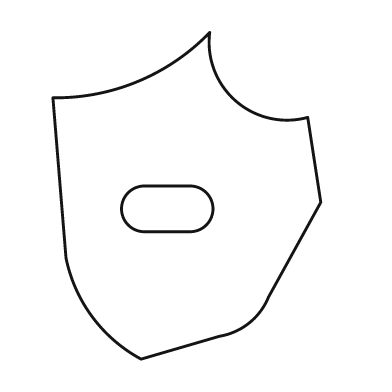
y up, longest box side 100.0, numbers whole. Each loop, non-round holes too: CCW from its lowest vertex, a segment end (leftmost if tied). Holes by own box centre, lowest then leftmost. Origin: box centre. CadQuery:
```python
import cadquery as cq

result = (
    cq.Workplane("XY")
    .moveTo(-14.0, -50.0)
    .lineTo(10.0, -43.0)
    .threePointArc((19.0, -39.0), (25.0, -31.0))
    .lineTo(41.0, -2.0)
    .lineTo(37.0, 24.0)
    .threePointArc((15.0, 29.0), (7.0, 50.0))
    .threePointArc((-15.0, 35.0), (-41.0, 30.0))
    .lineTo(-37.0, -19.0)
    .threePointArc((-29.0, -37.0), (-14.0, -50.0))
    .close()
    .moveTo(-13.0, -11.0)
    .lineTo(1.0, -11.0)
    .threePointArc((8.0, -4.0), (1.0, 3.0))
    .lineTo(-13.0, 3.0)
    .threePointArc((-20.0, -4.0), (-13.0, -11.0))
    .close()
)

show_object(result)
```